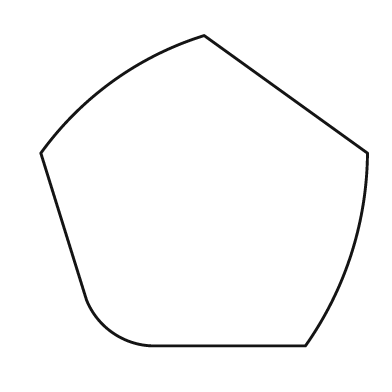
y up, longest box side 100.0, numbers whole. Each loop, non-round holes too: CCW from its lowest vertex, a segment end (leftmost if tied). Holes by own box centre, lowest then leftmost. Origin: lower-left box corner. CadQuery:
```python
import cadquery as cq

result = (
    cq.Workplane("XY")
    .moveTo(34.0, 0.0)
    .lineTo(81.0, 0.0)
    .threePointArc((95.0, 28.0), (100.0, 59.0))
    .lineTo(50.0, 95.0)
    .threePointArc((22.0, 81.0), (0.0, 59.0))
    .lineTo(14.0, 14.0)
    .threePointArc((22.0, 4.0), (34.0, 0.0))
    .close()
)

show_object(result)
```